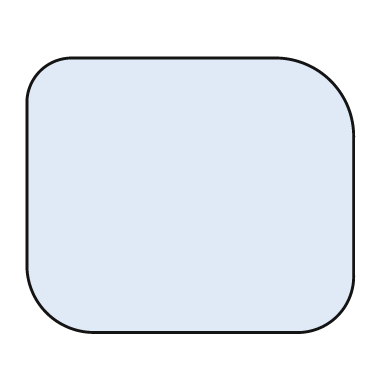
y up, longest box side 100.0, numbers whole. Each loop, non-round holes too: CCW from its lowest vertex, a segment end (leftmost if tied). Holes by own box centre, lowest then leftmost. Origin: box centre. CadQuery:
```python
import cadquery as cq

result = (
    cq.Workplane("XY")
    .moveTo(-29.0, -42.0)
    .lineTo(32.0, -42.0)
    .threePointArc((45.0, -37.0), (50.0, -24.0))
    .lineTo(50.0, 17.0)
    .threePointArc((43.0, 35.0), (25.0, 42.0))
    .lineTo(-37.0, 42.0)
    .threePointArc((-46.0, 38.0), (-50.0, 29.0))
    .lineTo(-50.0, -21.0)
    .threePointArc((-44.0, -36.0), (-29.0, -42.0))
    .close()
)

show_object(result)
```